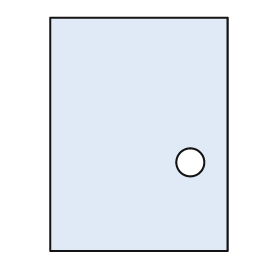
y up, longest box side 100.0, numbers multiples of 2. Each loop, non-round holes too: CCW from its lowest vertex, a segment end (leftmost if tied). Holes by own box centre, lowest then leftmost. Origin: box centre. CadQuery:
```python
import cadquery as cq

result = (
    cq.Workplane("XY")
    .moveTo(-38.0, -50.0)
    .lineTo(38.0, -50.0)
    .lineTo(38.0, 50.0)
    .lineTo(-38.0, 50.0)
    .close()
    .moveTo(22.0, -12.0)
    .circle(6.0)
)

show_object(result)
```